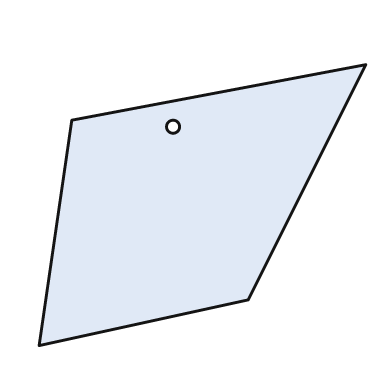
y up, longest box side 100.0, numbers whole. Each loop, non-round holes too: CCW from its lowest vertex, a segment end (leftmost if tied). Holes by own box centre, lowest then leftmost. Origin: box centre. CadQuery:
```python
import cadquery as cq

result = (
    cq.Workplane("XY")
    .moveTo(-50.0, -43.0)
    .lineTo(14.0, -29.0)
    .lineTo(50.0, 43.0)
    .lineTo(-40.0, 26.0)
    .close()
    .moveTo(-9.0, 24.0)
    .circle(2.0)
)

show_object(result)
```